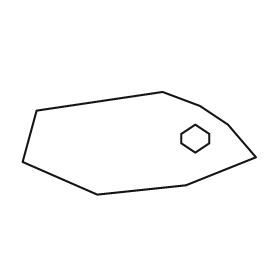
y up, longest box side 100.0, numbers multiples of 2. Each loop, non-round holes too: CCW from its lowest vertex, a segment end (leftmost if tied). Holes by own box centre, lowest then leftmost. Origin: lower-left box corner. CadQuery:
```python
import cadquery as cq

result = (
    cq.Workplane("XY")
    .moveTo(32.0, 0.0)
    .lineTo(70.0, 4.0)
    .lineTo(100.0, 16.0)
    .lineTo(88.0, 30.0)
    .lineTo(76.0, 38.0)
    .lineTo(60.0, 44.0)
    .lineTo(6.0, 36.0)
    .lineTo(0.0, 14.0)
    .close()
    .moveTo(74.0, 18.0)
    .lineTo(80.0, 22.0)
    .lineTo(80.0, 26.0)
    .lineTo(74.0, 30.0)
    .lineTo(68.0, 26.0)
    .lineTo(68.0, 22.0)
    .close()
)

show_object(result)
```